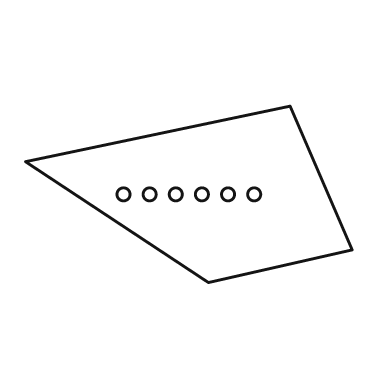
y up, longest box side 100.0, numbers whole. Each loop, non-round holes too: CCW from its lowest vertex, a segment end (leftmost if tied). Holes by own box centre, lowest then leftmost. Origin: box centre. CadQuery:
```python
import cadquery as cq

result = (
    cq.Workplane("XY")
    .moveTo(6.0, -27.0)
    .lineTo(50.0, -17.0)
    .lineTo(31.0, 27.0)
    .lineTo(-50.0, 10.0)
    .close()
    .moveTo(-20.0, 0.0)
    .circle(2.0)
    .moveTo(-12.0, 0.0)
    .circle(2.0)
    .moveTo(-4.0, 0.0)
    .circle(2.0)
    .moveTo(4.0, 0.0)
    .circle(2.0)
    .moveTo(12.0, 0.0)
    .circle(2.0)
    .moveTo(20.0, 0.0)
    .circle(2.0)
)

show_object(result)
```